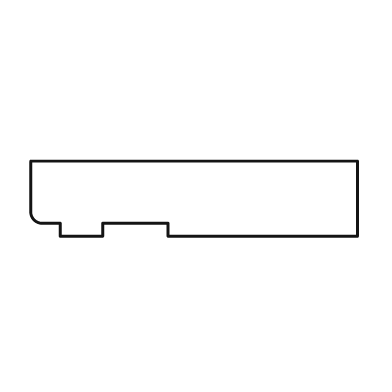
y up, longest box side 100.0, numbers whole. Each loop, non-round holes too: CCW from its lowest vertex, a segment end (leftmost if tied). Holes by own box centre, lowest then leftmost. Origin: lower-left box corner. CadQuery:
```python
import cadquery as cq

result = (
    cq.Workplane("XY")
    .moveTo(9.0, 0.0)
    .lineTo(22.0, 0.0)
    .lineTo(22.0, 4.0)
    .lineTo(42.0, 4.0)
    .lineTo(42.0, 0.0)
    .lineTo(100.0, 0.0)
    .lineTo(100.0, 23.0)
    .lineTo(0.0, 23.0)
    .lineTo(0.0, 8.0)
    .threePointArc((1.0, 5.0), (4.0, 4.0))
    .lineTo(9.0, 4.0)
    .close()
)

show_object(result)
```